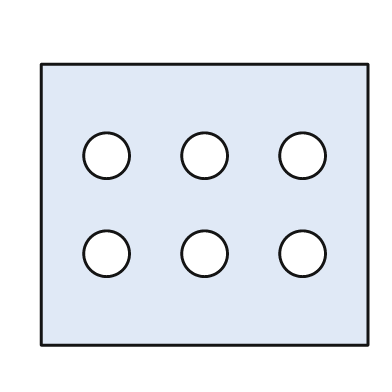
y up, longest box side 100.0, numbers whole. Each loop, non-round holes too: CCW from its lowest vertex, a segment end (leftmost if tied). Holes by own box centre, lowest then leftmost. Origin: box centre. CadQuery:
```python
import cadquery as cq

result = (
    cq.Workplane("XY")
    .moveTo(-50.0, -43.0)
    .lineTo(50.0, -43.0)
    .lineTo(50.0, 43.0)
    .lineTo(-50.0, 43.0)
    .close()
    .moveTo(-30.0, -15.0)
    .circle(7.0)
    .moveTo(0.0, -15.0)
    .circle(7.0)
    .moveTo(30.0, -15.0)
    .circle(7.0)
    .moveTo(-30.0, 15.0)
    .circle(7.0)
    .moveTo(0.0, 15.0)
    .circle(7.0)
    .moveTo(30.0, 15.0)
    .circle(7.0)
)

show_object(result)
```